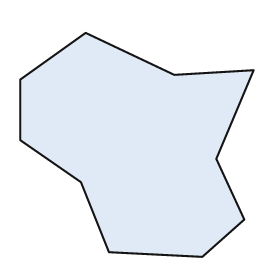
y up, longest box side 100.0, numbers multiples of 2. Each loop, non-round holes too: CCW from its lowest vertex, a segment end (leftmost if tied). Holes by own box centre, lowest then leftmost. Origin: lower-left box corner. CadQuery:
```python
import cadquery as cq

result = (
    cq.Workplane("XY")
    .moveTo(78.0, 0.0)
    .lineTo(96.0, 16.0)
    .lineTo(84.0, 42.0)
    .lineTo(100.0, 80.0)
    .lineTo(66.0, 78.0)
    .lineTo(28.0, 96.0)
    .lineTo(0.0, 76.0)
    .lineTo(0.0, 50.0)
    .lineTo(26.0, 32.0)
    .lineTo(38.0, 2.0)
    .close()
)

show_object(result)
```